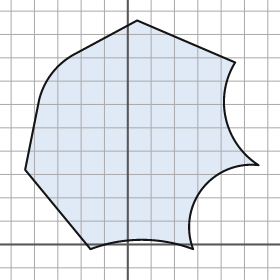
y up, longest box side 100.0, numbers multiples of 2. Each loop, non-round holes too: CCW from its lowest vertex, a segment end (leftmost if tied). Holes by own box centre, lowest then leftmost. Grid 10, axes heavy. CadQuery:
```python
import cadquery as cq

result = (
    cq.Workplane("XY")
    .moveTo(-16.0, -2.0)
    .threePointArc((6.0, 2.0), (28.0, -2.0))
    .threePointArc((32.0, 24.0), (56.0, 34.0))
    .threePointArc((42.0, 54.0), (46.0, 78.0))
    .lineTo(4.0, 96.0)
    .lineTo(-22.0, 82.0)
    .threePointArc((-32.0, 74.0), (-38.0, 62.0))
    .lineTo(-44.0, 32.0)
    .close()
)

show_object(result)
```